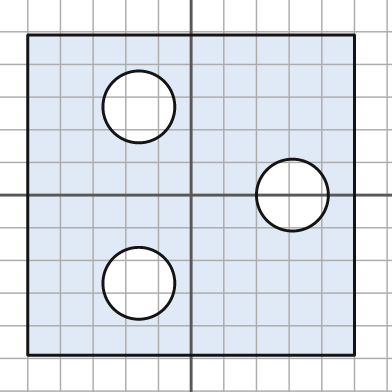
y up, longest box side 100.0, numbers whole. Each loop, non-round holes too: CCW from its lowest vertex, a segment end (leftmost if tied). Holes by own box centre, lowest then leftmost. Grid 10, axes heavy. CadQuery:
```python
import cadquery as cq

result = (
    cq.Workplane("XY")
    .moveTo(-50.0, -49.0)
    .lineTo(50.0, -49.0)
    .lineTo(50.0, 49.0)
    .lineTo(-50.0, 49.0)
    .close()
    .moveTo(-16.0, -27.0)
    .circle(11.0)
    .moveTo(31.0, 0.0)
    .circle(11.0)
    .moveTo(-16.0, 27.0)
    .circle(11.0)
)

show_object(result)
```